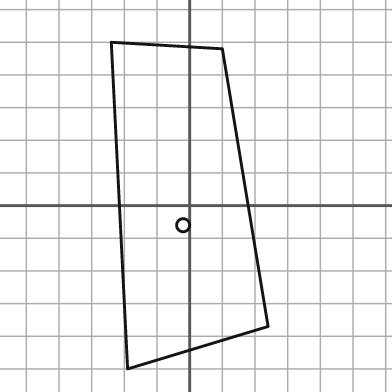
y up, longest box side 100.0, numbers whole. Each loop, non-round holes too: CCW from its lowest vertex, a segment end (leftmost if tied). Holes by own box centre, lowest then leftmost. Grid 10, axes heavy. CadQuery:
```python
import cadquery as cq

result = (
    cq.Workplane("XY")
    .moveTo(-19.0, -50.0)
    .lineTo(24.0, -37.0)
    .lineTo(10.0, 48.0)
    .lineTo(-24.0, 50.0)
    .close()
    .moveTo(-2.0, -6.0)
    .circle(2.0)
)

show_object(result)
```